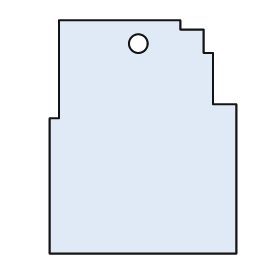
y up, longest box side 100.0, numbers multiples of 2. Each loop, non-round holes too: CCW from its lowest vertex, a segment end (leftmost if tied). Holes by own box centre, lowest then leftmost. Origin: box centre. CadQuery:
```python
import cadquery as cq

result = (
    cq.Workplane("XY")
    .moveTo(-40.0, -50.0)
    .lineTo(40.0, -50.0)
    .lineTo(40.0, 14.0)
    .lineTo(30.0, 14.0)
    .lineTo(30.0, 36.0)
    .lineTo(26.0, 36.0)
    .lineTo(26.0, 46.0)
    .lineTo(16.0, 46.0)
    .lineTo(16.0, 50.0)
    .lineTo(-36.0, 50.0)
    .lineTo(-36.0, 8.0)
    .lineTo(-40.0, 8.0)
    .close()
    .moveTo(-2.0, 40.0)
    .circle(4.0)
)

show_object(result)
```